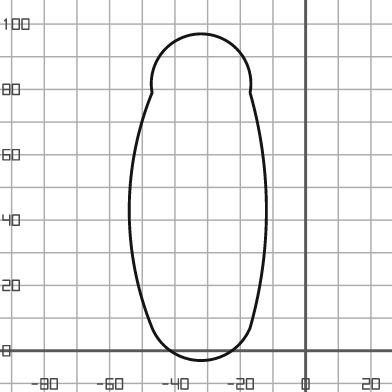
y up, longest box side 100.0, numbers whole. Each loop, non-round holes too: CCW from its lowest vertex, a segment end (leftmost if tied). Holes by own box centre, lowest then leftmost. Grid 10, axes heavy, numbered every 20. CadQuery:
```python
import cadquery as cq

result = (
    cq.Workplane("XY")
    .moveTo(-47.0, 7.0)
    .threePointArc((-32.0, -3.0), (-17.0, 7.0))
    .threePointArc((-12.0, 43.0), (-17.0, 79.0))
    .threePointArc((-32.0, 97.0), (-47.0, 79.0))
    .threePointArc((-54.0, 43.0), (-47.0, 7.0))
    .close()
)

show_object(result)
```